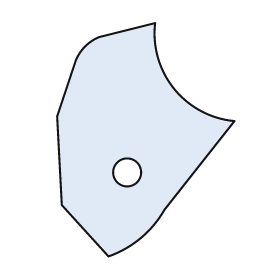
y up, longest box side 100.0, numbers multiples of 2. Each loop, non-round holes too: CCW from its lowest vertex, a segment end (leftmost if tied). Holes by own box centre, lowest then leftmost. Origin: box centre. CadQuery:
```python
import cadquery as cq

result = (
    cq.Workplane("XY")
    .moveTo(-16.0, -50.0)
    .threePointArc((-2.0, -42.0), (8.0, -30.0))
    .lineTo(38.0, 8.0)
    .threePointArc((12.0, 22.0), (4.0, 50.0))
    .lineTo(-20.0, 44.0)
    .threePointArc((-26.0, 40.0), (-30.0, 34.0))
    .lineTo(-38.0, 10.0)
    .lineTo(-36.0, -28.0)
    .close()
    .moveTo(-8.0, -14.0)
    .circle(6.0)
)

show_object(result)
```